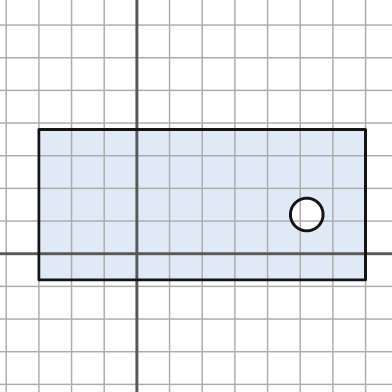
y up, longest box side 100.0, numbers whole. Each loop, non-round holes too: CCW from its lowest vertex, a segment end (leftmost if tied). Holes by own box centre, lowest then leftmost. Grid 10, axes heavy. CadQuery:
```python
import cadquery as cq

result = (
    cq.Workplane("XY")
    .moveTo(-30.0, -8.0)
    .lineTo(70.0, -8.0)
    .lineTo(70.0, 38.0)
    .lineTo(-30.0, 38.0)
    .close()
    .moveTo(52.0, 12.0)
    .circle(5.0)
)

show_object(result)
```